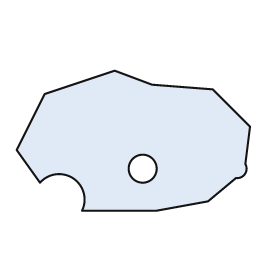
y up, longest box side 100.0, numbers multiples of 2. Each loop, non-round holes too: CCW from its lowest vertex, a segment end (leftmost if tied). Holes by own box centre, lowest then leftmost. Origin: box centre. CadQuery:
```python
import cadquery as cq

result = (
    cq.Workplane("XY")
    .moveTo(-22.0, -30.0)
    .lineTo(10.0, -30.0)
    .lineTo(32.0, -26.0)
    .lineTo(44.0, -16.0)
    .threePointArc((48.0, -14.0), (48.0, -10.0))
    .lineTo(50.0, 6.0)
    .lineTo(34.0, 22.0)
    .lineTo(8.0, 24.0)
    .lineTo(-8.0, 30.0)
    .lineTo(-38.0, 20.0)
    .lineTo(-50.0, -4.0)
    .lineTo(-40.0, -18.0)
    .threePointArc((-26.0, -16.0), (-22.0, -30.0))
    .close()
    .moveTo(4.0, -12.0)
    .circle(6.0)
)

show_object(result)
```